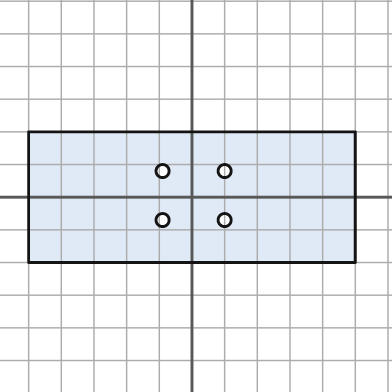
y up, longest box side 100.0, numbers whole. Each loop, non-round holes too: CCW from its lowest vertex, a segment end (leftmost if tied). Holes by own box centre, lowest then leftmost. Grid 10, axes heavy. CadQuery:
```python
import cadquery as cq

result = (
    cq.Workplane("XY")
    .moveTo(-50.0, -20.0)
    .lineTo(50.0, -20.0)
    .lineTo(50.0, 20.0)
    .lineTo(-50.0, 20.0)
    .close()
    .moveTo(-9.0, -7.0)
    .circle(2.0)
    .moveTo(10.0, -7.0)
    .circle(2.0)
    .moveTo(-9.0, 8.0)
    .circle(2.0)
    .moveTo(10.0, 8.0)
    .circle(2.0)
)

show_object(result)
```